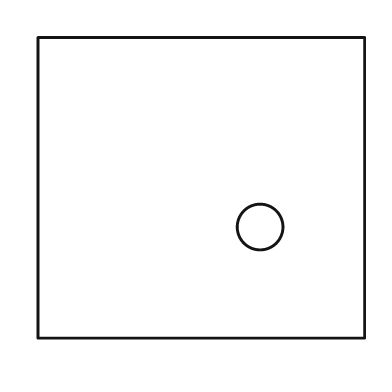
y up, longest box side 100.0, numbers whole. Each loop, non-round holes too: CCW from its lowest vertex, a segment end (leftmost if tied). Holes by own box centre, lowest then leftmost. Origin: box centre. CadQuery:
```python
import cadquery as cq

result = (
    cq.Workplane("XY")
    .moveTo(-50.0, -46.0)
    .lineTo(50.0, -46.0)
    .lineTo(50.0, 46.0)
    .lineTo(-50.0, 46.0)
    .close()
    .moveTo(18.0, -12.0)
    .circle(7.0)
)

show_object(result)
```